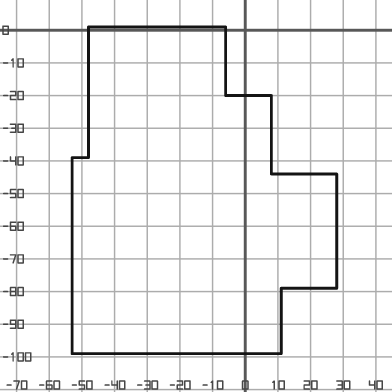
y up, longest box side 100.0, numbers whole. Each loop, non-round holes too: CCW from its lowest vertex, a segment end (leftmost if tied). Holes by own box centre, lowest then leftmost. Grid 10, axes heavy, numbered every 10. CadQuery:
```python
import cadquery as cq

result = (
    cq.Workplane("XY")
    .moveTo(-53.0, -99.0)
    .lineTo(11.0, -99.0)
    .lineTo(11.0, -79.0)
    .lineTo(28.0, -79.0)
    .lineTo(28.0, -44.0)
    .lineTo(8.0, -44.0)
    .lineTo(8.0, -20.0)
    .lineTo(-6.0, -20.0)
    .lineTo(-6.0, 1.0)
    .lineTo(-48.0, 1.0)
    .lineTo(-48.0, -39.0)
    .lineTo(-53.0, -39.0)
    .close()
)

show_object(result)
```